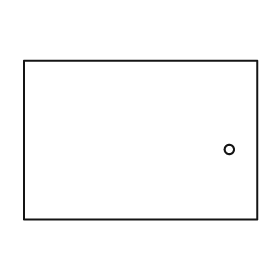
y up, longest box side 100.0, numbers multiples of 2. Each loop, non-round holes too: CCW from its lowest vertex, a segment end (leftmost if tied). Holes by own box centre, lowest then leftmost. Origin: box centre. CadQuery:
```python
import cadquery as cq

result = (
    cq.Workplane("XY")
    .moveTo(-50.0, -34.0)
    .lineTo(50.0, -34.0)
    .lineTo(50.0, 34.0)
    .lineTo(-50.0, 34.0)
    .close()
    .moveTo(38.0, -4.0)
    .circle(2.0)
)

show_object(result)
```